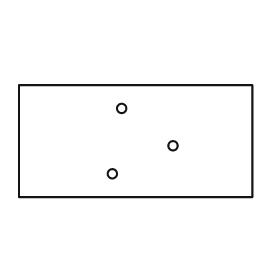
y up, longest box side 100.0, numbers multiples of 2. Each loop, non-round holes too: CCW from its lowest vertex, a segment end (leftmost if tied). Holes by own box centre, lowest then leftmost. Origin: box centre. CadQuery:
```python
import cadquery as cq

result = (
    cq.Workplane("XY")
    .moveTo(-50.0, -24.0)
    .lineTo(50.0, -24.0)
    .lineTo(50.0, 24.0)
    .lineTo(-50.0, 24.0)
    .close()
    .moveTo(-10.0, -14.0)
    .circle(2.0)
    .moveTo(16.0, -2.0)
    .circle(2.0)
    .moveTo(-6.0, 14.0)
    .circle(2.0)
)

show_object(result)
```